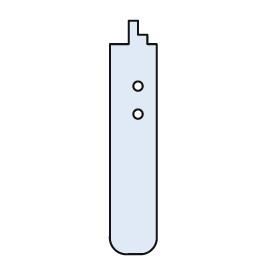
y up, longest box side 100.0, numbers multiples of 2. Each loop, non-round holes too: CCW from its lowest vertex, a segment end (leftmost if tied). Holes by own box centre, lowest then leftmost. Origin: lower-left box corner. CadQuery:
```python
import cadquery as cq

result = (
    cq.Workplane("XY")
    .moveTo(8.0, 0.0)
    .lineTo(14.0, 0.0)
    .threePointArc((18.0, 2.0), (20.0, 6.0))
    .lineTo(20.0, 90.0)
    .lineTo(16.0, 90.0)
    .lineTo(16.0, 94.0)
    .lineTo(12.0, 94.0)
    .lineTo(12.0, 100.0)
    .lineTo(8.0, 100.0)
    .lineTo(8.0, 90.0)
    .lineTo(0.0, 90.0)
    .lineTo(0.0, 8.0)
    .threePointArc((2.0, 2.0), (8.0, 0.0))
    .close()
    .moveTo(12.0, 60.0)
    .circle(2.0)
    .moveTo(12.0, 72.0)
    .circle(2.0)
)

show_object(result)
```